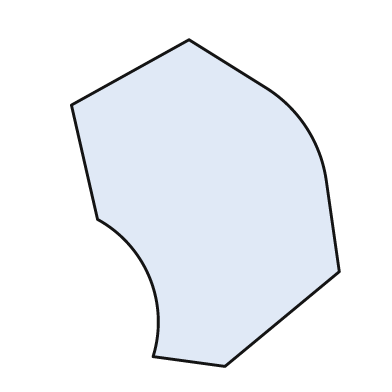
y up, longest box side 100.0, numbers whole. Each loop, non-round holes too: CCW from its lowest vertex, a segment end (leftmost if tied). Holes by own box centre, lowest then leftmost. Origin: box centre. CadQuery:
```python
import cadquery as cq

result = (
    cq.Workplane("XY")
    .moveTo(6.0, -50.0)
    .lineTo(41.0, -21.0)
    .lineTo(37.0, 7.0)
    .threePointArc((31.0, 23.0), (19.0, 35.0))
    .lineTo(-5.0, 50.0)
    .lineTo(-41.0, 30.0)
    .lineTo(-33.0, -5.0)
    .threePointArc((-17.0, -23.0), (-16.0, -47.0))
    .close()
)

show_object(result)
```